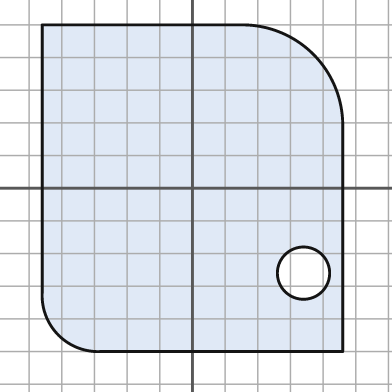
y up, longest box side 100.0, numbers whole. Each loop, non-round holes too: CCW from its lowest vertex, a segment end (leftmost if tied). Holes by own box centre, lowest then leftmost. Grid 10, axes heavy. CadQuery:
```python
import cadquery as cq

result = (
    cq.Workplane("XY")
    .moveTo(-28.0, -50.0)
    .lineTo(46.0, -50.0)
    .lineTo(46.0, 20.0)
    .threePointArc((37.0, 41.0), (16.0, 50.0))
    .lineTo(-46.0, 50.0)
    .lineTo(-46.0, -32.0)
    .threePointArc((-41.0, -45.0), (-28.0, -50.0))
    .close()
    .moveTo(34.0, -26.0)
    .circle(8.0)
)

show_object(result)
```